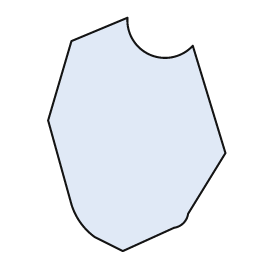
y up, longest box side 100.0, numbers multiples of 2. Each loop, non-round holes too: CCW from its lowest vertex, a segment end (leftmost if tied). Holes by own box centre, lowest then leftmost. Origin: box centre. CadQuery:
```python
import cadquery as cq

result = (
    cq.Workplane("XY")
    .moveTo(-6.0, -50.0)
    .lineTo(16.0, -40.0)
    .threePointArc((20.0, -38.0), (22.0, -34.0))
    .lineTo(38.0, -8.0)
    .lineTo(24.0, 38.0)
    .threePointArc((6.0, 34.0), (-4.0, 50.0))
    .lineTo(-28.0, 40.0)
    .lineTo(-38.0, 6.0)
    .lineTo(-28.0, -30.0)
    .threePointArc((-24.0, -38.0), (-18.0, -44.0))
    .close()
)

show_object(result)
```